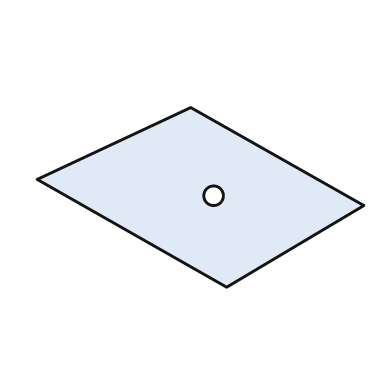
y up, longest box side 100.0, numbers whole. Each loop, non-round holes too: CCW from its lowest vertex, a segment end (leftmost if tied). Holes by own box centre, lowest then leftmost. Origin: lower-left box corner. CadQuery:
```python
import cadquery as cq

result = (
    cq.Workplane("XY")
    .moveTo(58.0, 0.0)
    .lineTo(100.0, 25.0)
    .lineTo(47.0, 55.0)
    .lineTo(0.0, 33.0)
    .close()
    .moveTo(54.0, 28.0)
    .circle(3.0)
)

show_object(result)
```